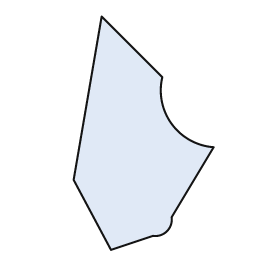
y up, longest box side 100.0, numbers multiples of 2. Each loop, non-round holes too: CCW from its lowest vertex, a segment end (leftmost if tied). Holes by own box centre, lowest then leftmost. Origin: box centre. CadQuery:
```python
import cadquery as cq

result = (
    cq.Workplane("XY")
    .moveTo(-14.0, -50.0)
    .lineTo(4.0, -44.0)
    .threePointArc((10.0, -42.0), (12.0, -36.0))
    .lineTo(30.0, -6.0)
    .threePointArc((12.0, 4.0), (8.0, 24.0))
    .lineTo(-18.0, 50.0)
    .lineTo(-30.0, -20.0)
    .close()
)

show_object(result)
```